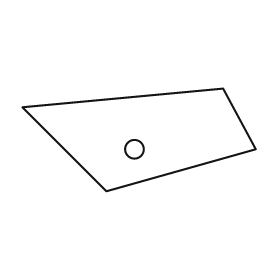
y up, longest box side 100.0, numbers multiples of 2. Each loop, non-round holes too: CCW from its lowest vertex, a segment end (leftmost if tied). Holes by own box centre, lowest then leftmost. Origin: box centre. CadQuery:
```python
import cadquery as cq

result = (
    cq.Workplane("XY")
    .moveTo(-14.0, -22.0)
    .lineTo(50.0, -4.0)
    .lineTo(36.0, 22.0)
    .lineTo(-50.0, 14.0)
    .close()
    .moveTo(-2.0, -4.0)
    .circle(4.0)
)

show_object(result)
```